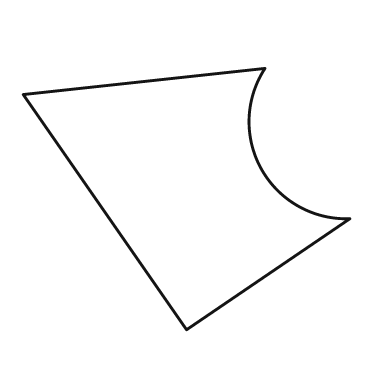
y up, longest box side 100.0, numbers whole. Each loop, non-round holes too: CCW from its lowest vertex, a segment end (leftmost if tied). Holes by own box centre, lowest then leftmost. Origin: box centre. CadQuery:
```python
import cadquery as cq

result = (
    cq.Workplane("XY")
    .moveTo(0.0, -40.0)
    .lineTo(50.0, -6.0)
    .threePointArc((23.0, 9.0), (24.0, 40.0))
    .lineTo(-50.0, 32.0)
    .close()
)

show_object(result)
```